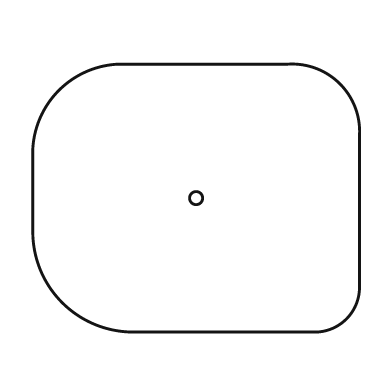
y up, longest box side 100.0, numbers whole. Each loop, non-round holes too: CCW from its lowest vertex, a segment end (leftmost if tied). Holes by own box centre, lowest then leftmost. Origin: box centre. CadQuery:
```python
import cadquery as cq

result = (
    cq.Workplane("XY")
    .moveTo(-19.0, -41.0)
    .lineTo(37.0, -41.0)
    .threePointArc((46.0, -37.0), (50.0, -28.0))
    .lineTo(50.0, 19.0)
    .threePointArc((44.0, 35.0), (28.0, 41.0))
    .lineTo(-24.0, 41.0)
    .threePointArc((-42.0, 33.0), (-50.0, 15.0))
    .lineTo(-50.0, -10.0)
    .threePointArc((-41.0, -32.0), (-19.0, -41.0))
    .close()
    .moveTo(0.0, 0.0)
    .circle(2.0)
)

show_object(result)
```